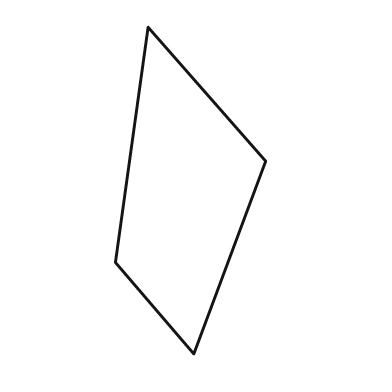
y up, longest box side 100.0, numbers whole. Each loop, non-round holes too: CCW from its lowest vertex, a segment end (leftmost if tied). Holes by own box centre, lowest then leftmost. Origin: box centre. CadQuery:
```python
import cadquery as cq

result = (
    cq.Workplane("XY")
    .moveTo(1.0, -50.0)
    .lineTo(23.0, 9.0)
    .lineTo(-13.0, 50.0)
    .lineTo(-23.0, -22.0)
    .close()
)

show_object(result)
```